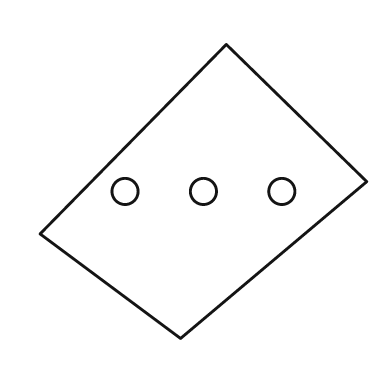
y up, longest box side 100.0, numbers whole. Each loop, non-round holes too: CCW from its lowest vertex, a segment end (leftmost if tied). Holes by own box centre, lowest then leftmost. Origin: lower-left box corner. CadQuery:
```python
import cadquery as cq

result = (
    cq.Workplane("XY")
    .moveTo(43.0, 0.0)
    .lineTo(100.0, 48.0)
    .lineTo(57.0, 90.0)
    .lineTo(0.0, 32.0)
    .close()
    .moveTo(26.0, 45.0)
    .circle(4.0)
    .moveTo(50.0, 45.0)
    .circle(4.0)
    .moveTo(74.0, 45.0)
    .circle(4.0)
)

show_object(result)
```